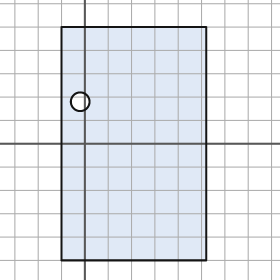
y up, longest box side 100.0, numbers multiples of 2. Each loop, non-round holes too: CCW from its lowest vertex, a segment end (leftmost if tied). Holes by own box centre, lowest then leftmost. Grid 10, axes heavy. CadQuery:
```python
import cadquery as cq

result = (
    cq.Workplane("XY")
    .moveTo(-10.0, -50.0)
    .lineTo(52.0, -50.0)
    .lineTo(52.0, 50.0)
    .lineTo(-10.0, 50.0)
    .close()
    .moveTo(-2.0, 18.0)
    .circle(4.0)
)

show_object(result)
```